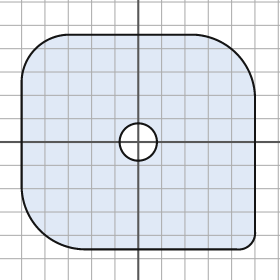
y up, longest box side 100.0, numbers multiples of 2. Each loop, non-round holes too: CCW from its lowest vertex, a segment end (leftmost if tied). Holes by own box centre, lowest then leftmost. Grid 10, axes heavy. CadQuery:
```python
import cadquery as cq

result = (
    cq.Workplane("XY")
    .moveTo(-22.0, -46.0)
    .lineTo(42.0, -46.0)
    .threePointArc((48.0, -44.0), (50.0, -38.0))
    .lineTo(50.0, 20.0)
    .threePointArc((42.0, 38.0), (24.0, 46.0))
    .lineTo(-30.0, 46.0)
    .threePointArc((-44.0, 40.0), (-50.0, 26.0))
    .lineTo(-50.0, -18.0)
    .threePointArc((-42.0, -38.0), (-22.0, -46.0))
    .close()
    .moveTo(0.0, 0.0)
    .circle(8.0)
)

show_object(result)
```